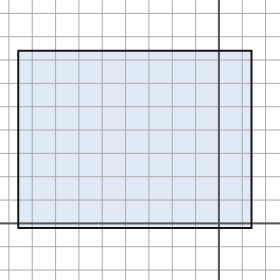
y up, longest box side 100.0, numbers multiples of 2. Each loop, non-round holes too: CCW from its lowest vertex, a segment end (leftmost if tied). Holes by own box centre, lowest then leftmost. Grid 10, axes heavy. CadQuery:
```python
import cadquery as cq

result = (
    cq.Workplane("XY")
    .moveTo(-86.0, -2.0)
    .lineTo(14.0, -2.0)
    .lineTo(14.0, 74.0)
    .lineTo(-86.0, 74.0)
    .close()
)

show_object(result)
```